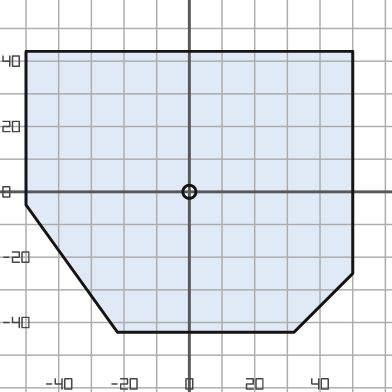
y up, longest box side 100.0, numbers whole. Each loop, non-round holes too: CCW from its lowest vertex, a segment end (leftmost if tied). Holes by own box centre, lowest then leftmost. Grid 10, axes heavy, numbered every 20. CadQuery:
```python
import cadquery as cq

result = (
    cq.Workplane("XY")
    .moveTo(-22.0, -43.0)
    .lineTo(32.0, -43.0)
    .lineTo(50.0, -25.0)
    .lineTo(50.0, 43.0)
    .lineTo(-50.0, 43.0)
    .lineTo(-50.0, -4.0)
    .close()
    .moveTo(0.0, 0.0)
    .circle(2.0)
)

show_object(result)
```